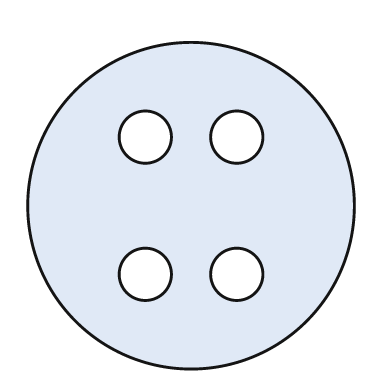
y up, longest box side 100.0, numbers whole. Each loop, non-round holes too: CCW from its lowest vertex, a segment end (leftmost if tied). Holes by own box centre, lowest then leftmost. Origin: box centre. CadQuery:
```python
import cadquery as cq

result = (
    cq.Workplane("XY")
    .moveTo(0.0, 0.0)
    .circle(50.0)
    .moveTo(-14.0, -21.0)
    .circle(8.0)
    .moveTo(14.0, -21.0)
    .circle(8.0)
    .moveTo(-14.0, 21.0)
    .circle(8.0)
    .moveTo(14.0, 21.0)
    .circle(8.0)
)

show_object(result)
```